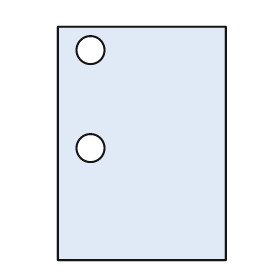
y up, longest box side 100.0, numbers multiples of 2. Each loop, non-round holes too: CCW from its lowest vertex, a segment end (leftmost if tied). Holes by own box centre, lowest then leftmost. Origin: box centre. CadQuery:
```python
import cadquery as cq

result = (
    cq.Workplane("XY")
    .moveTo(-36.0, -50.0)
    .lineTo(36.0, -50.0)
    .lineTo(36.0, 50.0)
    .lineTo(-36.0, 50.0)
    .close()
    .moveTo(-22.0, -2.0)
    .circle(6.0)
    .moveTo(-22.0, 40.0)
    .circle(6.0)
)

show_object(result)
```